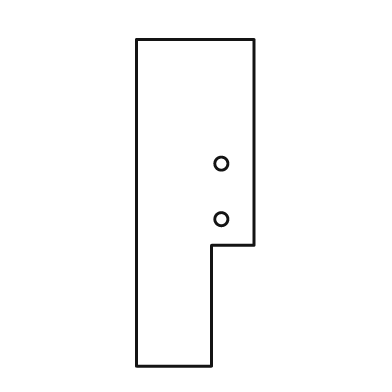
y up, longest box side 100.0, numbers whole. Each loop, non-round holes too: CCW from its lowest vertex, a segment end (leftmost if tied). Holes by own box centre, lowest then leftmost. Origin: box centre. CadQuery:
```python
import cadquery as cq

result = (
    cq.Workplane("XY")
    .moveTo(-18.0, -50.0)
    .lineTo(5.0, -50.0)
    .lineTo(5.0, -13.0)
    .lineTo(18.0, -13.0)
    .lineTo(18.0, 50.0)
    .lineTo(-18.0, 50.0)
    .close()
    .moveTo(8.0, -5.0)
    .circle(2.0)
    .moveTo(8.0, 12.0)
    .circle(2.0)
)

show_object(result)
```